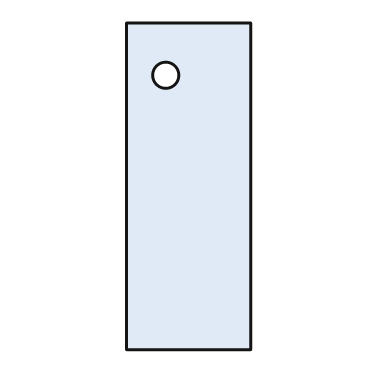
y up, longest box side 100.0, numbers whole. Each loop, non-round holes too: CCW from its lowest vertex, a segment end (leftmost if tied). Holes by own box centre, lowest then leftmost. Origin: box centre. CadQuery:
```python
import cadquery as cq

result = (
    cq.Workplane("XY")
    .moveTo(-19.0, -50.0)
    .lineTo(19.0, -50.0)
    .lineTo(19.0, 50.0)
    .lineTo(-19.0, 50.0)
    .close()
    .moveTo(-7.0, 34.0)
    .circle(4.0)
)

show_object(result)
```